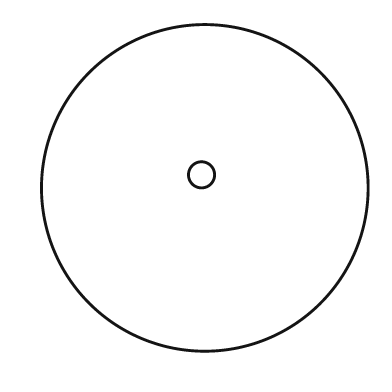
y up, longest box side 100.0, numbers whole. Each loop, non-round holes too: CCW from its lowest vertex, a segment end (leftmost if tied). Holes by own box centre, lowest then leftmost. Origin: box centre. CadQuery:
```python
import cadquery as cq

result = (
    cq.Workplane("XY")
    .moveTo(0.0, 0.0)
    .circle(50.0)
    .moveTo(-1.0, 4.0)
    .circle(4.0)
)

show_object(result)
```